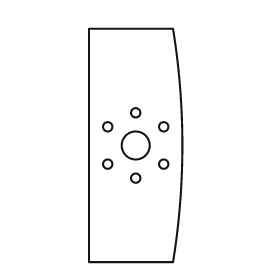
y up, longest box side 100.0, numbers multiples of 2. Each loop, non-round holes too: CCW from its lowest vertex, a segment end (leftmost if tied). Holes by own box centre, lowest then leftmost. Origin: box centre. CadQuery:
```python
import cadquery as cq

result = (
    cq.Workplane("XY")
    .moveTo(-20.0, -50.0)
    .lineTo(16.0, -50.0)
    .threePointArc((20.0, 0.0), (16.0, 50.0))
    .lineTo(-20.0, 50.0)
    .close()
    .moveTo(0.0, -14.0)
    .circle(2.0)
    .moveTo(-12.0, -8.0)
    .circle(2.0)
    .moveTo(12.0, -8.0)
    .circle(2.0)
    .moveTo(0.0, 0.0)
    .circle(6.0)
    .moveTo(-12.0, 8.0)
    .circle(2.0)
    .moveTo(12.0, 8.0)
    .circle(2.0)
    .moveTo(0.0, 14.0)
    .circle(2.0)
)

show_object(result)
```